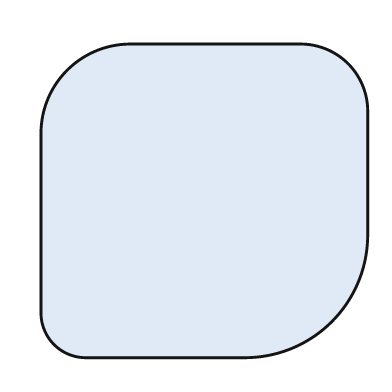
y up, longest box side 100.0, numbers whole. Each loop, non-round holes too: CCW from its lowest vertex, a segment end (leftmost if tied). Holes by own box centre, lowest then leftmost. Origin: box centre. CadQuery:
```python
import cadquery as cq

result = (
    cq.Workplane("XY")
    .moveTo(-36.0, -48.0)
    .lineTo(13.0, -48.0)
    .threePointArc((39.0, -37.0), (50.0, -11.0))
    .lineTo(50.0, 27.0)
    .threePointArc((44.0, 42.0), (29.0, 48.0))
    .lineTo(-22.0, 48.0)
    .threePointArc((-42.0, 40.0), (-50.0, 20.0))
    .lineTo(-50.0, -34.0)
    .threePointArc((-46.0, -44.0), (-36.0, -48.0))
    .close()
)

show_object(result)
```